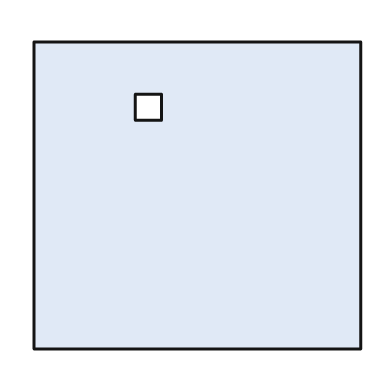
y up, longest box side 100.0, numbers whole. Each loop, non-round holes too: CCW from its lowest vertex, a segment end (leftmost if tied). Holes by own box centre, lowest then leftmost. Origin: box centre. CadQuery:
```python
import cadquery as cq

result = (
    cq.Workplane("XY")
    .moveTo(-50.0, -47.0)
    .lineTo(50.0, -47.0)
    .lineTo(50.0, 47.0)
    .lineTo(-50.0, 47.0)
    .close()
    .moveTo(-19.0, 23.0)
    .lineTo(-11.0, 23.0)
    .lineTo(-11.0, 31.0)
    .lineTo(-19.0, 31.0)
    .close()
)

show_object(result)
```